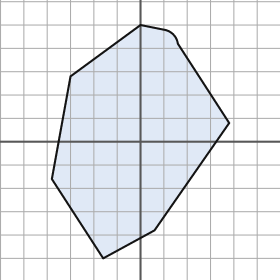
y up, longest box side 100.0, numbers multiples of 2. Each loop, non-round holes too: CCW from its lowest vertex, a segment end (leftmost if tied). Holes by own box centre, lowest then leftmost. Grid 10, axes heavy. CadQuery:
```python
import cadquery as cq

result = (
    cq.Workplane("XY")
    .moveTo(-16.0, -50.0)
    .lineTo(6.0, -38.0)
    .lineTo(38.0, 8.0)
    .lineTo(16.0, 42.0)
    .threePointArc((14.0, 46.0), (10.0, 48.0))
    .lineTo(0.0, 50.0)
    .lineTo(-30.0, 28.0)
    .lineTo(-38.0, -16.0)
    .close()
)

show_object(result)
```